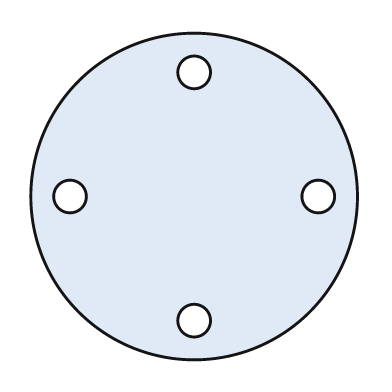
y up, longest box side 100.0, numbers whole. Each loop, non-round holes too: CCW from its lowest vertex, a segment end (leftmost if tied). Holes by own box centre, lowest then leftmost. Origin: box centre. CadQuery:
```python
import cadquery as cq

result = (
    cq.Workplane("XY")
    .moveTo(0.0, 0.0)
    .circle(50.0)
    .moveTo(0.0, -38.0)
    .circle(5.0)
    .moveTo(-38.0, 0.0)
    .circle(5.0)
    .moveTo(38.0, 0.0)
    .circle(5.0)
    .moveTo(0.0, 38.0)
    .circle(5.0)
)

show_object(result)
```